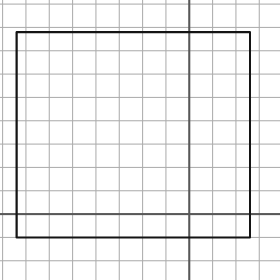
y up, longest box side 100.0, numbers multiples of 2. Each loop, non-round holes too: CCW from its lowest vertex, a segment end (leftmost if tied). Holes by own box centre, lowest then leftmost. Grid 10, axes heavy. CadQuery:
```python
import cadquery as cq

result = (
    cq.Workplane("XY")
    .moveTo(-74.0, -10.0)
    .lineTo(26.0, -10.0)
    .lineTo(26.0, 78.0)
    .lineTo(-74.0, 78.0)
    .close()
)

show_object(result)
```